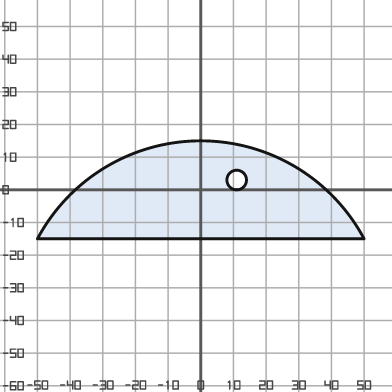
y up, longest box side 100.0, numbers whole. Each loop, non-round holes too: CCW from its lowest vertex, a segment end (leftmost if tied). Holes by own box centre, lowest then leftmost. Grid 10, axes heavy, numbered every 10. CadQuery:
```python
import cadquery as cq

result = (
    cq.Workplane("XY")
    .moveTo(-50.0, -15.0)
    .lineTo(50.0, -15.0)
    .threePointArc((0.0, 15.0), (-50.0, -15.0))
    .close()
    .moveTo(11.0, 3.0)
    .circle(3.0)
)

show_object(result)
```